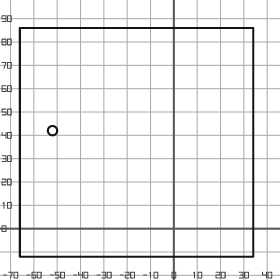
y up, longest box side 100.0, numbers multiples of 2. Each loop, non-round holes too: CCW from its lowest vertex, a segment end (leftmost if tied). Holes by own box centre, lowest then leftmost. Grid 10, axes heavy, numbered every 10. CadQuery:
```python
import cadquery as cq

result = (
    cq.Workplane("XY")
    .moveTo(-66.0, -12.0)
    .lineTo(34.0, -12.0)
    .lineTo(34.0, 86.0)
    .lineTo(-66.0, 86.0)
    .close()
    .moveTo(-52.0, 42.0)
    .circle(2.0)
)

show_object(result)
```